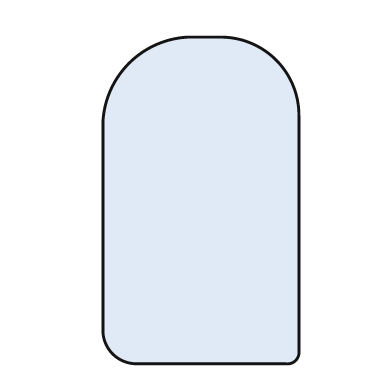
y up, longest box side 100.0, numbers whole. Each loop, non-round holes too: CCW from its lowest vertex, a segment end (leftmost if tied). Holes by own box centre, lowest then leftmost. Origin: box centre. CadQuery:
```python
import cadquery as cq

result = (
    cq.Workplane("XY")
    .moveTo(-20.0, -50.0)
    .lineTo(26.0, -50.0)
    .threePointArc((29.0, -49.0), (30.0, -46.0))
    .lineTo(30.0, 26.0)
    .threePointArc((23.0, 43.0), (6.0, 50.0))
    .lineTo(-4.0, 50.0)
    .threePointArc((-22.0, 42.0), (-30.0, 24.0))
    .lineTo(-30.0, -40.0)
    .threePointArc((-27.0, -47.0), (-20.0, -50.0))
    .close()
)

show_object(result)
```